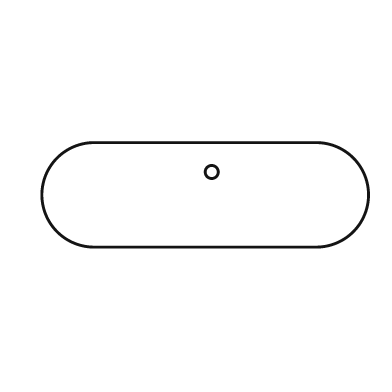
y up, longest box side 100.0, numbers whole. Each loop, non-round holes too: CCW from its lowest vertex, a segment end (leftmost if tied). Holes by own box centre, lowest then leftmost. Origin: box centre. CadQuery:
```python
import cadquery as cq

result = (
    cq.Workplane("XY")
    .moveTo(-34.0, -16.0)
    .lineTo(34.0, -16.0)
    .threePointArc((50.0, 0.0), (34.0, 16.0))
    .lineTo(-34.0, 16.0)
    .threePointArc((-50.0, 0.0), (-34.0, -16.0))
    .close()
    .moveTo(2.0, 7.0)
    .circle(2.0)
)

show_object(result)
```